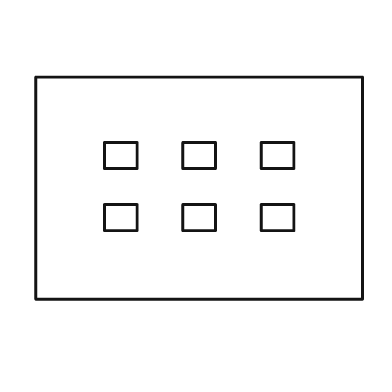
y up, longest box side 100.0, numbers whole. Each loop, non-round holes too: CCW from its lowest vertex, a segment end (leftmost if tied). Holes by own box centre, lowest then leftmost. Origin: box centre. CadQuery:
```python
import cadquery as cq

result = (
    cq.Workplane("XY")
    .moveTo(-50.0, -34.0)
    .lineTo(50.0, -34.0)
    .lineTo(50.0, 34.0)
    .lineTo(-50.0, 34.0)
    .close()
    .moveTo(-29.0, -13.0)
    .lineTo(-19.0, -13.0)
    .lineTo(-19.0, -5.0)
    .lineTo(-29.0, -5.0)
    .close()
    .moveTo(-5.0, -13.0)
    .lineTo(5.0, -13.0)
    .lineTo(5.0, -5.0)
    .lineTo(-5.0, -5.0)
    .close()
    .moveTo(19.0, -13.0)
    .lineTo(29.0, -13.0)
    .lineTo(29.0, -5.0)
    .lineTo(19.0, -5.0)
    .close()
    .moveTo(-29.0, 6.0)
    .lineTo(-19.0, 6.0)
    .lineTo(-19.0, 14.0)
    .lineTo(-29.0, 14.0)
    .close()
    .moveTo(-5.0, 6.0)
    .lineTo(5.0, 6.0)
    .lineTo(5.0, 14.0)
    .lineTo(-5.0, 14.0)
    .close()
    .moveTo(19.0, 6.0)
    .lineTo(29.0, 6.0)
    .lineTo(29.0, 14.0)
    .lineTo(19.0, 14.0)
    .close()
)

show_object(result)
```